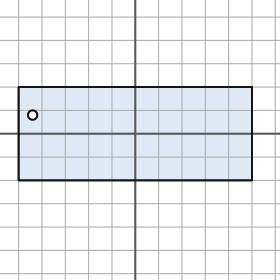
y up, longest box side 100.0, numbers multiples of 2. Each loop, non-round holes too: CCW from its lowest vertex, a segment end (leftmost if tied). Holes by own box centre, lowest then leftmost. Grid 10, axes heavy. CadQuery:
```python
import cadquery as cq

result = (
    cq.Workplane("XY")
    .moveTo(-50.0, -20.0)
    .lineTo(50.0, -20.0)
    .lineTo(50.0, 20.0)
    .lineTo(-50.0, 20.0)
    .close()
    .moveTo(-44.0, 8.0)
    .circle(2.0)
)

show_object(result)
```